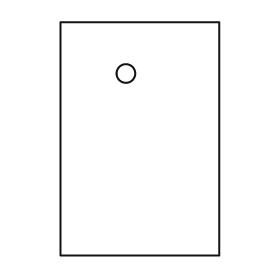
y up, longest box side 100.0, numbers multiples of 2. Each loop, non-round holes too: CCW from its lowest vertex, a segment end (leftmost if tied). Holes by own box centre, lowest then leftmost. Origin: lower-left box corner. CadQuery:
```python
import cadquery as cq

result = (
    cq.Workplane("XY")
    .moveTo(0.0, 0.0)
    .lineTo(68.0, 0.0)
    .lineTo(68.0, 100.0)
    .lineTo(0.0, 100.0)
    .close()
    .moveTo(28.0, 78.0)
    .circle(4.0)
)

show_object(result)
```